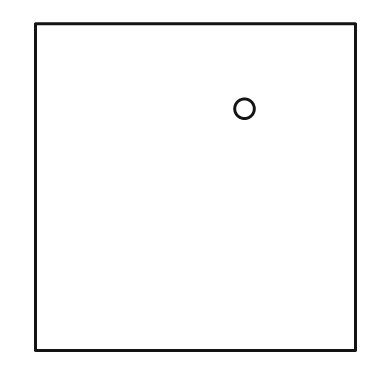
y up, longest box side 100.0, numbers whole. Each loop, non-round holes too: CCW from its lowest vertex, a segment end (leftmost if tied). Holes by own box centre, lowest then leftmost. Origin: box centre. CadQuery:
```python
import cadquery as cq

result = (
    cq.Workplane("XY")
    .moveTo(-49.0, -50.0)
    .lineTo(49.0, -50.0)
    .lineTo(49.0, 50.0)
    .lineTo(-49.0, 50.0)
    .close()
    .moveTo(15.0, 24.0)
    .circle(3.0)
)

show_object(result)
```